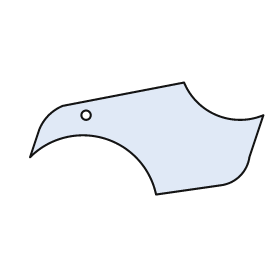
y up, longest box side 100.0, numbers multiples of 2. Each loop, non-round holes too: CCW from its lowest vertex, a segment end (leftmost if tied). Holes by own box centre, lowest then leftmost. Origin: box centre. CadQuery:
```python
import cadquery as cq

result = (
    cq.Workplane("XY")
    .moveTo(4.0, -24.0)
    .lineTo(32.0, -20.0)
    .threePointArc((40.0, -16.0), (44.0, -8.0))
    .lineTo(50.0, 10.0)
    .threePointArc((30.0, 10.0), (16.0, 24.0))
    .lineTo(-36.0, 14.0)
    .threePointArc((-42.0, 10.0), (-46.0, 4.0))
    .lineTo(-50.0, -8.0)
    .threePointArc((-18.0, 0.0), (4.0, -24.0))
    .close()
    .moveTo(-26.0, 10.0)
    .circle(2.0)
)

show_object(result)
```